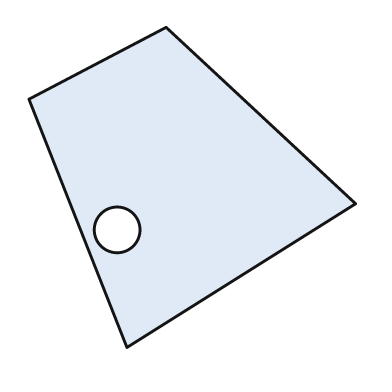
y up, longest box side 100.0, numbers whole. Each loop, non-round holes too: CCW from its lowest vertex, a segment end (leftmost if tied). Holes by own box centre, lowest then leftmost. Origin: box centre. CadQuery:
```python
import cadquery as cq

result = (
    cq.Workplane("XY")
    .moveTo(-20.0, -49.0)
    .lineTo(50.0, -5.0)
    .lineTo(-8.0, 49.0)
    .lineTo(-50.0, 27.0)
    .close()
    .moveTo(-23.0, -13.0)
    .circle(7.0)
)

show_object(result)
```